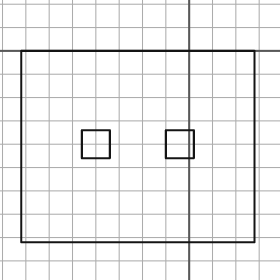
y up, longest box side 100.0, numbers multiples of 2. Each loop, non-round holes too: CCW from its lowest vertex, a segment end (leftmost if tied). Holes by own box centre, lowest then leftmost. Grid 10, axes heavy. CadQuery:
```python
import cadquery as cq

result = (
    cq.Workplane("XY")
    .moveTo(-72.0, -82.0)
    .lineTo(28.0, -82.0)
    .lineTo(28.0, 0.0)
    .lineTo(-72.0, 0.0)
    .close()
    .moveTo(-46.0, -46.0)
    .lineTo(-34.0, -46.0)
    .lineTo(-34.0, -34.0)
    .lineTo(-46.0, -34.0)
    .close()
    .moveTo(-10.0, -46.0)
    .lineTo(2.0, -46.0)
    .lineTo(2.0, -34.0)
    .lineTo(-10.0, -34.0)
    .close()
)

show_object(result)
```